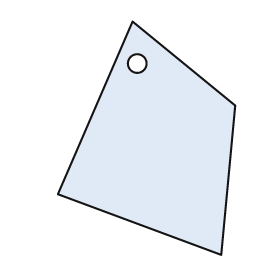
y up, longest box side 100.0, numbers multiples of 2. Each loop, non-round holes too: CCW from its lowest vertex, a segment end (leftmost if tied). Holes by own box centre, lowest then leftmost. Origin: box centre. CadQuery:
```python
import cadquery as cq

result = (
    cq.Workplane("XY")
    .moveTo(32.0, -50.0)
    .lineTo(38.0, 14.0)
    .lineTo(-6.0, 50.0)
    .lineTo(-38.0, -24.0)
    .close()
    .moveTo(-4.0, 32.0)
    .circle(4.0)
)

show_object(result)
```